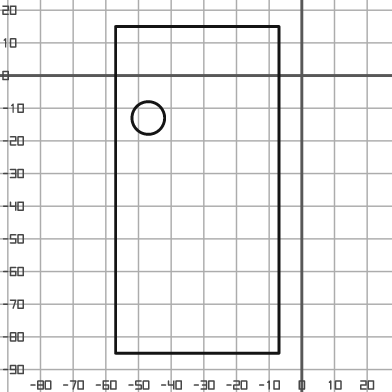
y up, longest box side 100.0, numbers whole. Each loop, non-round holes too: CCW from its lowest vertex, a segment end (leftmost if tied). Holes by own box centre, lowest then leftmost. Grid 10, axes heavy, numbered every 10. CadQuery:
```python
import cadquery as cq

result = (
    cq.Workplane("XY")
    .moveTo(-57.0, -85.0)
    .lineTo(-7.0, -85.0)
    .lineTo(-7.0, 15.0)
    .lineTo(-57.0, 15.0)
    .close()
    .moveTo(-47.0, -13.0)
    .circle(5.0)
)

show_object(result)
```